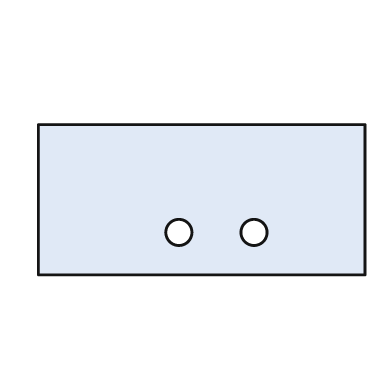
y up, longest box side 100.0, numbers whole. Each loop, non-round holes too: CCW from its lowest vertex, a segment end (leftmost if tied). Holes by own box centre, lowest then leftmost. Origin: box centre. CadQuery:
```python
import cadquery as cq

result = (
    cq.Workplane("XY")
    .moveTo(-50.0, -23.0)
    .lineTo(50.0, -23.0)
    .lineTo(50.0, 23.0)
    .lineTo(-50.0, 23.0)
    .close()
    .moveTo(-7.0, -10.0)
    .circle(4.0)
    .moveTo(16.0, -10.0)
    .circle(4.0)
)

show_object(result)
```